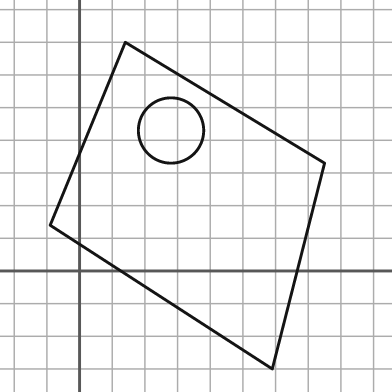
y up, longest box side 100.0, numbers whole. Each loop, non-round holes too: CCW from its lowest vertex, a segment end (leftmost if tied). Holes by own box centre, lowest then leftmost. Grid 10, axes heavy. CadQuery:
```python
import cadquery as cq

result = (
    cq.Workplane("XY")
    .moveTo(59.0, -30.0)
    .lineTo(75.0, 33.0)
    .lineTo(14.0, 70.0)
    .lineTo(-9.0, 14.0)
    .close()
    .moveTo(28.0, 43.0)
    .circle(10.0)
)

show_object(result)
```